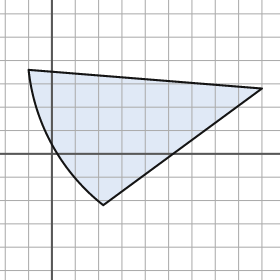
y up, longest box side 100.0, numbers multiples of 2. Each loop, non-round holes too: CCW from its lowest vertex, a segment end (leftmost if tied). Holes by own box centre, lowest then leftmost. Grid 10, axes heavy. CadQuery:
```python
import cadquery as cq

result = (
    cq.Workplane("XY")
    .moveTo(22.0, -22.0)
    .lineTo(90.0, 28.0)
    .lineTo(-10.0, 36.0)
    .threePointArc((0.0, 4.0), (22.0, -22.0))
    .close()
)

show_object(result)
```